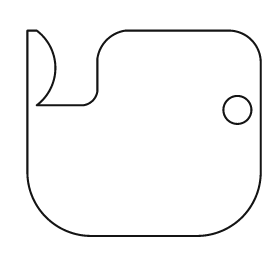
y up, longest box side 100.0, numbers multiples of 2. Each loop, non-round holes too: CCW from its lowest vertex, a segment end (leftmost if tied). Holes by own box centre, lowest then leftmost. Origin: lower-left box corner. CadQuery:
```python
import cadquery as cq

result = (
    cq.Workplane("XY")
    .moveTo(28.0, 0.0)
    .lineTo(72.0, 0.0)
    .threePointArc((92.0, 8.0), (100.0, 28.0))
    .lineTo(100.0, 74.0)
    .threePointArc((96.0, 84.0), (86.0, 88.0))
    .lineTo(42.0, 88.0)
    .threePointArc((34.0, 84.0), (30.0, 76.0))
    .lineTo(30.0, 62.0)
    .threePointArc((28.0, 58.0), (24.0, 56.0))
    .lineTo(4.0, 56.0)
    .threePointArc((12.0, 72.0), (4.0, 88.0))
    .lineTo(0.0, 88.0)
    .lineTo(0.0, 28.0)
    .threePointArc((8.0, 8.0), (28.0, 0.0))
    .close()
    .moveTo(90.0, 54.0)
    .circle(6.0)
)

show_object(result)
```